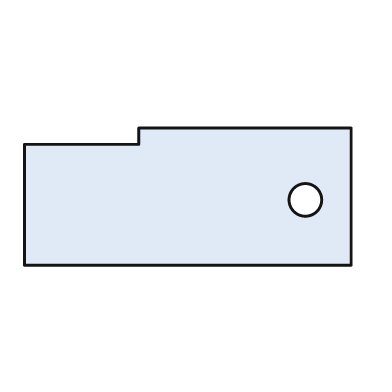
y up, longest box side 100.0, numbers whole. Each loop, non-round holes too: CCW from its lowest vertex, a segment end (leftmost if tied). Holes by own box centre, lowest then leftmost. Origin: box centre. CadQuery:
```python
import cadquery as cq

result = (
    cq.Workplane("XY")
    .moveTo(-50.0, -21.0)
    .lineTo(50.0, -21.0)
    .lineTo(50.0, 21.0)
    .lineTo(-15.0, 21.0)
    .lineTo(-15.0, 16.0)
    .lineTo(-50.0, 16.0)
    .close()
    .moveTo(36.0, -1.0)
    .circle(5.0)
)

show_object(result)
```